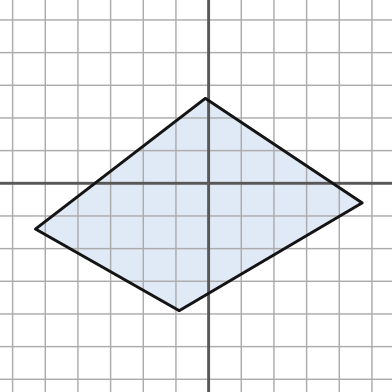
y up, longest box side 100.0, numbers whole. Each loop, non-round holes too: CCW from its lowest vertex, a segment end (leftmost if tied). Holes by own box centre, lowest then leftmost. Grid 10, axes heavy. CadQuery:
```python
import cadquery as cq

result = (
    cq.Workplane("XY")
    .moveTo(-9.0, -39.0)
    .lineTo(47.0, -6.0)
    .lineTo(-1.0, 26.0)
    .lineTo(-53.0, -14.0)
    .close()
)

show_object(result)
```